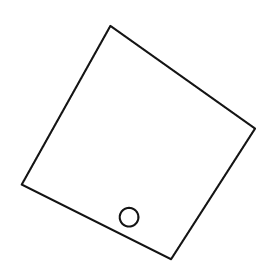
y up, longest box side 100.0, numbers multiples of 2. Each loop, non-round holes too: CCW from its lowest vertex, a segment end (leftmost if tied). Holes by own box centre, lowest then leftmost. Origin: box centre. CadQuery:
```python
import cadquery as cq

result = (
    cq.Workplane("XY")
    .moveTo(14.0, -50.0)
    .lineTo(50.0, 6.0)
    .lineTo(-12.0, 50.0)
    .lineTo(-50.0, -18.0)
    .close()
    .moveTo(-4.0, -32.0)
    .circle(4.0)
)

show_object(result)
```